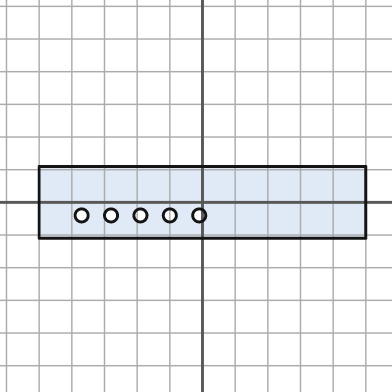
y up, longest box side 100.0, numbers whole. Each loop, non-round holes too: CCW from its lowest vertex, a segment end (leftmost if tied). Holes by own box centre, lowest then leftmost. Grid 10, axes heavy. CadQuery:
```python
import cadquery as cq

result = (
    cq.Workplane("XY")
    .moveTo(-50.0, -11.0)
    .lineTo(50.0, -11.0)
    .lineTo(50.0, 11.0)
    .lineTo(-50.0, 11.0)
    .close()
    .moveTo(-37.0, -4.0)
    .circle(2.0)
    .moveTo(-28.0, -4.0)
    .circle(2.0)
    .moveTo(-19.0, -4.0)
    .circle(2.0)
    .moveTo(-10.0, -4.0)
    .circle(2.0)
    .moveTo(-1.0, -4.0)
    .circle(2.0)
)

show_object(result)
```